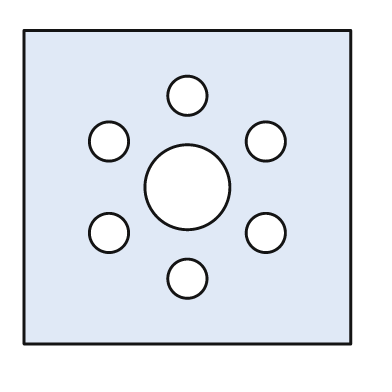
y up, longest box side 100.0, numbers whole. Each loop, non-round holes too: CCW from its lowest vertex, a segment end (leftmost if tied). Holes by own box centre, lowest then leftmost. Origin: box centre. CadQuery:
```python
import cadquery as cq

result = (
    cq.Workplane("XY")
    .moveTo(-50.0, -48.0)
    .lineTo(50.0, -48.0)
    .lineTo(50.0, 48.0)
    .lineTo(-50.0, 48.0)
    .close()
    .moveTo(0.0, -28.0)
    .circle(6.0)
    .moveTo(-24.0, -14.0)
    .circle(6.0)
    .moveTo(24.0, -14.0)
    .circle(6.0)
    .moveTo(0.0, 0.0)
    .circle(13.0)
    .moveTo(-24.0, 14.0)
    .circle(6.0)
    .moveTo(24.0, 14.0)
    .circle(6.0)
    .moveTo(0.0, 28.0)
    .circle(6.0)
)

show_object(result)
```